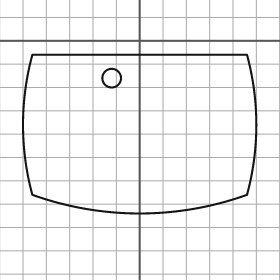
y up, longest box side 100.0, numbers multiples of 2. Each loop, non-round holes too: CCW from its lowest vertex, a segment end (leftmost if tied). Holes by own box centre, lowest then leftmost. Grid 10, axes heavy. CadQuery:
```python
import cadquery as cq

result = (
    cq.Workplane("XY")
    .moveTo(-46.0, -66.0)
    .threePointArc((0.0, -74.0), (46.0, -66.0))
    .threePointArc((50.0, -36.0), (46.0, -6.0))
    .lineTo(-46.0, -6.0)
    .threePointArc((-50.0, -36.0), (-46.0, -66.0))
    .close()
    .moveTo(-12.0, -16.0)
    .circle(4.0)
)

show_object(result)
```